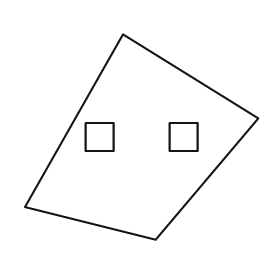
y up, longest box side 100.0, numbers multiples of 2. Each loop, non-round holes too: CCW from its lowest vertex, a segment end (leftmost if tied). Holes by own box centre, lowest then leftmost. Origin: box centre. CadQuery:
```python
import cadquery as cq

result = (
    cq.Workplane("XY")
    .moveTo(6.0, -44.0)
    .lineTo(50.0, 8.0)
    .lineTo(-8.0, 44.0)
    .lineTo(-50.0, -30.0)
    .close()
    .moveTo(-24.0, -6.0)
    .lineTo(-12.0, -6.0)
    .lineTo(-12.0, 6.0)
    .lineTo(-24.0, 6.0)
    .close()
    .moveTo(12.0, -6.0)
    .lineTo(24.0, -6.0)
    .lineTo(24.0, 6.0)
    .lineTo(12.0, 6.0)
    .close()
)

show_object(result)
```